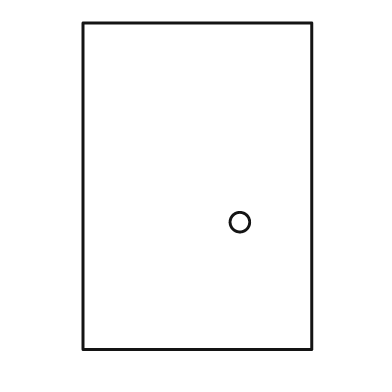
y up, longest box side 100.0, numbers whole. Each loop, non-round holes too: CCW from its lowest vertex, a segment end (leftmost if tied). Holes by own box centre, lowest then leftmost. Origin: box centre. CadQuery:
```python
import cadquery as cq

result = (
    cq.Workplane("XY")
    .moveTo(-35.0, -50.0)
    .lineTo(35.0, -50.0)
    .lineTo(35.0, 50.0)
    .lineTo(-35.0, 50.0)
    .close()
    .moveTo(13.0, -11.0)
    .circle(3.0)
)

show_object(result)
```